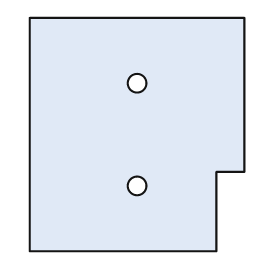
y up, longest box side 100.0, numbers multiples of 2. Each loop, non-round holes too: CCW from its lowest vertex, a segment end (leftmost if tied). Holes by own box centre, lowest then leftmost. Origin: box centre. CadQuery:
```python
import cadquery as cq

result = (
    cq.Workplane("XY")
    .moveTo(-46.0, -50.0)
    .lineTo(34.0, -50.0)
    .lineTo(34.0, -16.0)
    .lineTo(46.0, -16.0)
    .lineTo(46.0, 50.0)
    .lineTo(-46.0, 50.0)
    .close()
    .moveTo(0.0, -22.0)
    .circle(4.0)
    .moveTo(0.0, 22.0)
    .circle(4.0)
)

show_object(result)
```